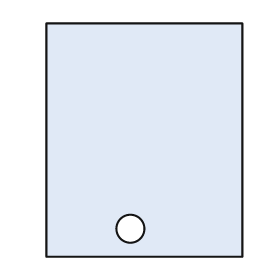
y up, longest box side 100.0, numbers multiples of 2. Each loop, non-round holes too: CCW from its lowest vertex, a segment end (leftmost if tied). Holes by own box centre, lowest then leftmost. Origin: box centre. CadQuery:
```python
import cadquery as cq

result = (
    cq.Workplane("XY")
    .moveTo(-42.0, -50.0)
    .lineTo(42.0, -50.0)
    .lineTo(42.0, 50.0)
    .lineTo(-42.0, 50.0)
    .close()
    .moveTo(-6.0, -38.0)
    .circle(6.0)
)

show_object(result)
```